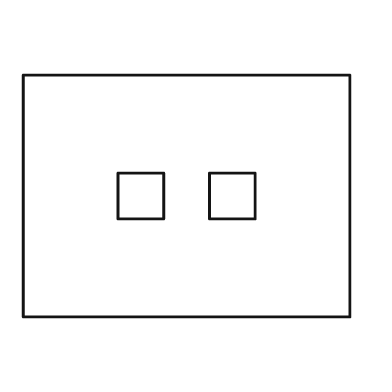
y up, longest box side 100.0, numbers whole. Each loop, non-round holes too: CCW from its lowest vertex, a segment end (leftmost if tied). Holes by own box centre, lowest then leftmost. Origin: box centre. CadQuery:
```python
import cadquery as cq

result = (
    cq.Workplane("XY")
    .moveTo(-50.0, -37.0)
    .lineTo(50.0, -37.0)
    .lineTo(50.0, 37.0)
    .lineTo(-50.0, 37.0)
    .close()
    .moveTo(-21.0, -7.0)
    .lineTo(-7.0, -7.0)
    .lineTo(-7.0, 7.0)
    .lineTo(-21.0, 7.0)
    .close()
    .moveTo(7.0, -7.0)
    .lineTo(21.0, -7.0)
    .lineTo(21.0, 7.0)
    .lineTo(7.0, 7.0)
    .close()
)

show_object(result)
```